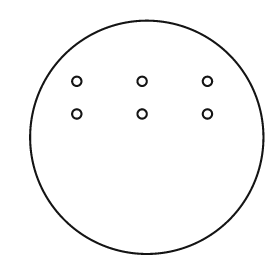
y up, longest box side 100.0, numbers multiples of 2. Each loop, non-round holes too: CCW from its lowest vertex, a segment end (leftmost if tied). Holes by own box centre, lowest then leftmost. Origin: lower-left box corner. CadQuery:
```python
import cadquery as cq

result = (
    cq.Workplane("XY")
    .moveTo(50.0, 50.0)
    .circle(50.0)
    .moveTo(20.0, 60.0)
    .circle(2.0)
    .moveTo(48.0, 60.0)
    .circle(2.0)
    .moveTo(76.0, 60.0)
    .circle(2.0)
    .moveTo(20.0, 74.0)
    .circle(2.0)
    .moveTo(48.0, 74.0)
    .circle(2.0)
    .moveTo(76.0, 74.0)
    .circle(2.0)
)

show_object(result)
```